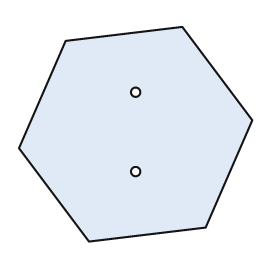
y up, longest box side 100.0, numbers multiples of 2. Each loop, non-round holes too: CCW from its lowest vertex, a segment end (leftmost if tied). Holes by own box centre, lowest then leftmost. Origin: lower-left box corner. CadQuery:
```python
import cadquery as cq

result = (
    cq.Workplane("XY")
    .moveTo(30.0, 0.0)
    .lineTo(80.0, 6.0)
    .lineTo(100.0, 52.0)
    .lineTo(70.0, 92.0)
    .lineTo(20.0, 86.0)
    .lineTo(0.0, 40.0)
    .close()
    .moveTo(50.0, 30.0)
    .circle(2.0)
    .moveTo(50.0, 64.0)
    .circle(2.0)
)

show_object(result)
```